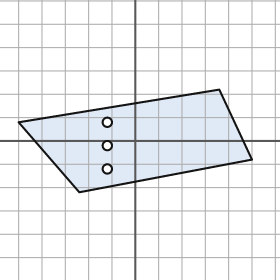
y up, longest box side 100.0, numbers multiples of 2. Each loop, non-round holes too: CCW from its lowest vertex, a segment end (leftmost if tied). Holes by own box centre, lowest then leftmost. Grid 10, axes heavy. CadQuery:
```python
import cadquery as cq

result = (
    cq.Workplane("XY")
    .moveTo(-24.0, -22.0)
    .lineTo(50.0, -8.0)
    .lineTo(36.0, 22.0)
    .lineTo(-50.0, 8.0)
    .close()
    .moveTo(-12.0, -12.0)
    .circle(2.0)
    .moveTo(-12.0, -2.0)
    .circle(2.0)
    .moveTo(-12.0, 8.0)
    .circle(2.0)
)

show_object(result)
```